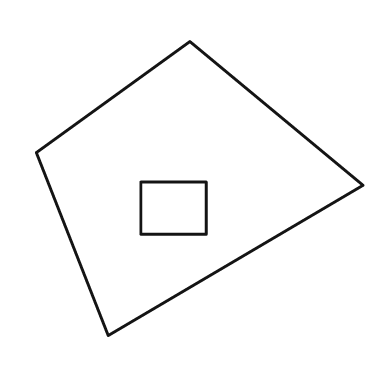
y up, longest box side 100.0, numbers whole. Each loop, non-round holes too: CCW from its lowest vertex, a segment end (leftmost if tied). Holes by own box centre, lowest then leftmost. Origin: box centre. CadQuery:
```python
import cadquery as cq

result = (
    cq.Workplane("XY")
    .moveTo(-28.0, -45.0)
    .lineTo(50.0, 1.0)
    .lineTo(-3.0, 45.0)
    .lineTo(-50.0, 11.0)
    .close()
    .moveTo(-18.0, -14.0)
    .lineTo(2.0, -14.0)
    .lineTo(2.0, 2.0)
    .lineTo(-18.0, 2.0)
    .close()
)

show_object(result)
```